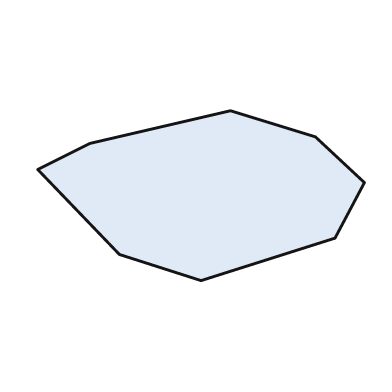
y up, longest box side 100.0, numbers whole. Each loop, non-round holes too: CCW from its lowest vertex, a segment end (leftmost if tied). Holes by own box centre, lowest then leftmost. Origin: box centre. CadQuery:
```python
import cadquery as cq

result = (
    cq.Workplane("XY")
    .moveTo(0.0, -26.0)
    .lineTo(41.0, -13.0)
    .lineTo(50.0, 4.0)
    .lineTo(35.0, 18.0)
    .lineTo(9.0, 26.0)
    .lineTo(-34.0, 16.0)
    .lineTo(-50.0, 8.0)
    .lineTo(-25.0, -18.0)
    .close()
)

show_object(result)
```